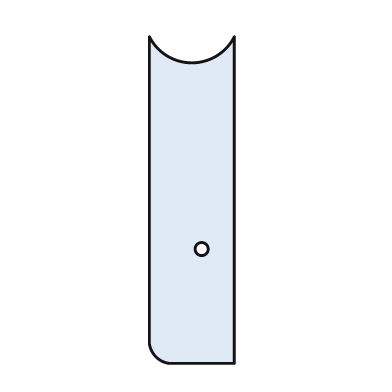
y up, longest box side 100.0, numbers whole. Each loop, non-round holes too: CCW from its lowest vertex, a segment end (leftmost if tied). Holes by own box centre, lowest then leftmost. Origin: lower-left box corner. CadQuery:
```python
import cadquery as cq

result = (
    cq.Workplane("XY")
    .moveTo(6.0, 0.0)
    .lineTo(26.0, 0.0)
    .lineTo(26.0, 100.0)
    .threePointArc((13.0, 92.0), (0.0, 100.0))
    .lineTo(0.0, 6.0)
    .threePointArc((2.0, 2.0), (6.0, 0.0))
    .close()
    .moveTo(16.0, 35.0)
    .circle(2.0)
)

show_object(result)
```